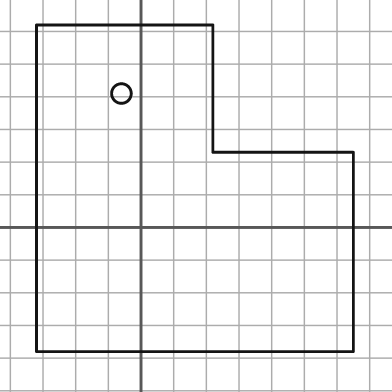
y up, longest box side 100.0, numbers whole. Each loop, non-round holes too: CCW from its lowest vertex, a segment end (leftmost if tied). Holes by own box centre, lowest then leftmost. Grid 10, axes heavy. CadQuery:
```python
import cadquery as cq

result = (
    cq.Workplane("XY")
    .moveTo(-32.0, -38.0)
    .lineTo(65.0, -38.0)
    .lineTo(65.0, 23.0)
    .lineTo(22.0, 23.0)
    .lineTo(22.0, 62.0)
    .lineTo(-32.0, 62.0)
    .close()
    .moveTo(-6.0, 41.0)
    .circle(3.0)
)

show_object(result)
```